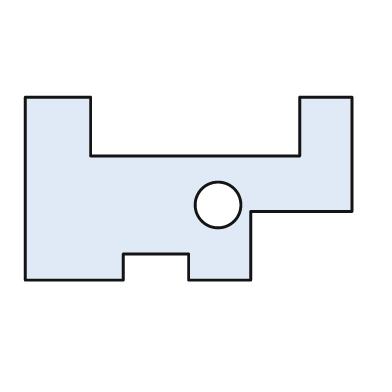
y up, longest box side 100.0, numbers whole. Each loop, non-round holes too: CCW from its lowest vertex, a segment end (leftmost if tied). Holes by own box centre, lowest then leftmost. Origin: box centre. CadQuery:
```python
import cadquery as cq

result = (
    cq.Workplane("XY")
    .moveTo(-50.0, -28.0)
    .lineTo(-20.0, -28.0)
    .lineTo(-20.0, -20.0)
    .lineTo(0.0, -20.0)
    .lineTo(0.0, -28.0)
    .lineTo(19.0, -28.0)
    .lineTo(19.0, -7.0)
    .lineTo(50.0, -7.0)
    .lineTo(50.0, 28.0)
    .lineTo(34.0, 28.0)
    .lineTo(34.0, 10.0)
    .lineTo(-30.0, 10.0)
    .lineTo(-30.0, 28.0)
    .lineTo(-50.0, 28.0)
    .close()
    .moveTo(9.0, -5.0)
    .circle(7.0)
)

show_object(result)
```